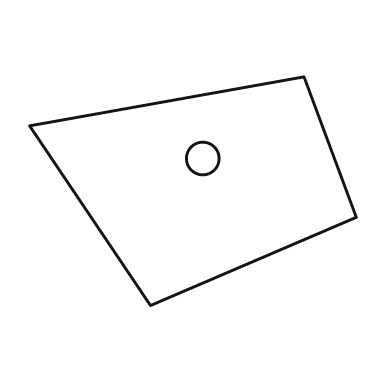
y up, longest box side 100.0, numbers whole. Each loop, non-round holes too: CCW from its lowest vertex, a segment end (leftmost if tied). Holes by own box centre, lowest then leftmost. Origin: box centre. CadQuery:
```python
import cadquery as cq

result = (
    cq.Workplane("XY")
    .moveTo(-13.0, -35.0)
    .lineTo(50.0, -8.0)
    .lineTo(34.0, 35.0)
    .lineTo(-50.0, 20.0)
    .close()
    .moveTo(3.0, 10.0)
    .circle(5.0)
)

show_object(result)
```